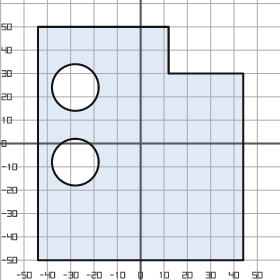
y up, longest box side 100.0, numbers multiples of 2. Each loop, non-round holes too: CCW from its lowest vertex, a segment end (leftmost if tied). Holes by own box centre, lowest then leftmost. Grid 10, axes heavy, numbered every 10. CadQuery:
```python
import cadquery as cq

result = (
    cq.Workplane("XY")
    .moveTo(-44.0, -50.0)
    .lineTo(44.0, -50.0)
    .lineTo(44.0, 30.0)
    .lineTo(12.0, 30.0)
    .lineTo(12.0, 50.0)
    .lineTo(-44.0, 50.0)
    .close()
    .moveTo(-28.0, -8.0)
    .circle(10.0)
    .moveTo(-28.0, 24.0)
    .circle(10.0)
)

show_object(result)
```